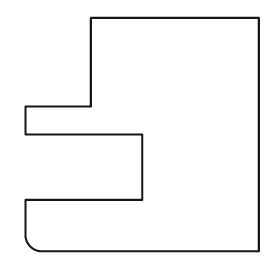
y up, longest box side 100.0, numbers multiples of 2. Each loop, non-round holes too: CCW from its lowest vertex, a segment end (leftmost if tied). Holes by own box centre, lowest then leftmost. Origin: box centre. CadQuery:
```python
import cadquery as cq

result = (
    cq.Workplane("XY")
    .moveTo(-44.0, -50.0)
    .lineTo(50.0, -50.0)
    .lineTo(50.0, 50.0)
    .lineTo(-22.0, 50.0)
    .lineTo(-22.0, 12.0)
    .lineTo(-50.0, 12.0)
    .lineTo(-50.0, 0.0)
    .lineTo(0.0, 0.0)
    .lineTo(0.0, -28.0)
    .lineTo(-50.0, -28.0)
    .lineTo(-50.0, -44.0)
    .threePointArc((-48.0, -48.0), (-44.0, -50.0))
    .close()
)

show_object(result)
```